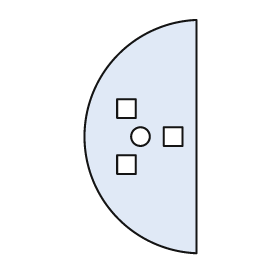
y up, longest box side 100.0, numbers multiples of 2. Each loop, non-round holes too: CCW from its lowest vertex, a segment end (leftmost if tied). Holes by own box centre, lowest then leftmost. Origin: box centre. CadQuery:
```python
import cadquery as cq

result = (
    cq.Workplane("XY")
    .moveTo(24.0, -50.0)
    .lineTo(24.0, 50.0)
    .threePointArc((-24.0, 0.0), (24.0, -50.0))
    .close()
    .moveTo(-10.0, -16.0)
    .lineTo(-2.0, -16.0)
    .lineTo(-2.0, -8.0)
    .lineTo(-10.0, -8.0)
    .close()
    .moveTo(0.0, 0.0)
    .circle(4.0)
    .moveTo(10.0, -4.0)
    .lineTo(18.0, -4.0)
    .lineTo(18.0, 4.0)
    .lineTo(10.0, 4.0)
    .close()
    .moveTo(-10.0, 8.0)
    .lineTo(-2.0, 8.0)
    .lineTo(-2.0, 16.0)
    .lineTo(-10.0, 16.0)
    .close()
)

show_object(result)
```